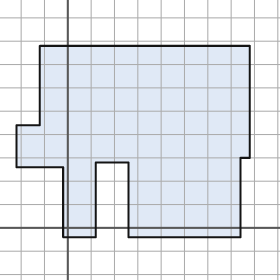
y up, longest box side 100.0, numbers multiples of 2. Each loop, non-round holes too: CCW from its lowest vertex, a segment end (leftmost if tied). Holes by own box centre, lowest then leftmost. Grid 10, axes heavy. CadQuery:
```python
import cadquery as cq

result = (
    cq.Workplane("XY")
    .moveTo(-2.0, -4.0)
    .lineTo(12.0, -4.0)
    .lineTo(12.0, 28.0)
    .lineTo(26.0, 28.0)
    .lineTo(26.0, -4.0)
    .lineTo(74.0, -4.0)
    .lineTo(74.0, 30.0)
    .lineTo(78.0, 30.0)
    .lineTo(78.0, 78.0)
    .lineTo(-12.0, 78.0)
    .lineTo(-12.0, 44.0)
    .lineTo(-22.0, 44.0)
    .lineTo(-22.0, 26.0)
    .lineTo(-2.0, 26.0)
    .close()
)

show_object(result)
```